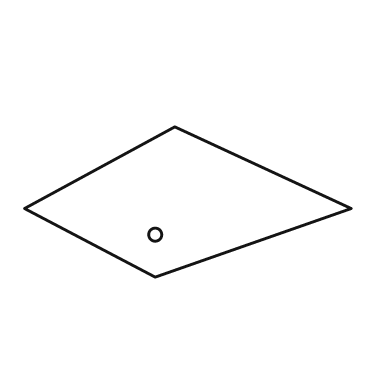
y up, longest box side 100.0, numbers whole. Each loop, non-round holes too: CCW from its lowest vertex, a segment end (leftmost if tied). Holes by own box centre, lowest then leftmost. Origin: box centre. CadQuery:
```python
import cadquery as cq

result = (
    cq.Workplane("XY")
    .moveTo(-10.0, -23.0)
    .lineTo(50.0, -2.0)
    .lineTo(-4.0, 23.0)
    .lineTo(-50.0, -2.0)
    .close()
    .moveTo(-10.0, -10.0)
    .circle(2.0)
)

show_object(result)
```